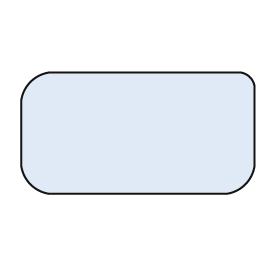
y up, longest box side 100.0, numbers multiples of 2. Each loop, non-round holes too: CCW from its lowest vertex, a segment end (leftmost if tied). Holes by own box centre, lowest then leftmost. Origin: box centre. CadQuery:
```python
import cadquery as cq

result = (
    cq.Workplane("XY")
    .moveTo(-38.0, -26.0)
    .lineTo(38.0, -26.0)
    .threePointArc((46.0, -22.0), (50.0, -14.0))
    .lineTo(50.0, 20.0)
    .threePointArc((48.0, 24.0), (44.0, 26.0))
    .lineTo(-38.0, 26.0)
    .threePointArc((-46.0, 22.0), (-50.0, 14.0))
    .lineTo(-50.0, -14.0)
    .threePointArc((-46.0, -22.0), (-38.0, -26.0))
    .close()
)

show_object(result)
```